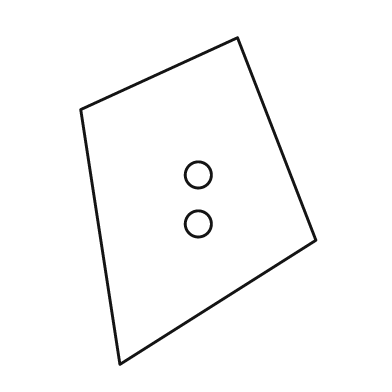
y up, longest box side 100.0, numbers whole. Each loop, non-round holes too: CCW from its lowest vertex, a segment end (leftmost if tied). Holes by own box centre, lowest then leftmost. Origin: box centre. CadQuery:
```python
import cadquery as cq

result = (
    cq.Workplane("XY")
    .moveTo(-24.0, -50.0)
    .lineTo(36.0, -12.0)
    .lineTo(12.0, 50.0)
    .lineTo(-36.0, 28.0)
    .close()
    .moveTo(0.0, -7.0)
    .circle(4.0)
    .moveTo(0.0, 8.0)
    .circle(4.0)
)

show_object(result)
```